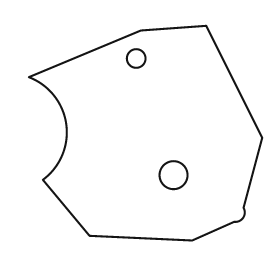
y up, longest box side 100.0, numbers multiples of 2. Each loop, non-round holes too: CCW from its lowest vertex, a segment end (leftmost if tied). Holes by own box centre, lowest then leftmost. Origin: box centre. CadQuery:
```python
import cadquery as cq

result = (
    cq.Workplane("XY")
    .moveTo(20.0, -46.0)
    .lineTo(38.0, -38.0)
    .threePointArc((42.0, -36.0), (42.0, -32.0))
    .lineTo(50.0, -2.0)
    .lineTo(26.0, 46.0)
    .lineTo(-2.0, 44.0)
    .lineTo(-50.0, 24.0)
    .threePointArc((-34.0, 4.0), (-44.0, -20.0))
    .lineTo(-24.0, -44.0)
    .close()
    .moveTo(12.0, -18.0)
    .circle(6.0)
    .moveTo(-4.0, 32.0)
    .circle(4.0)
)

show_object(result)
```